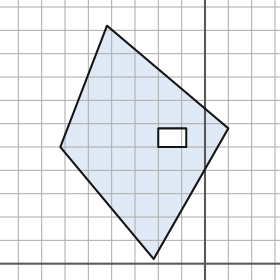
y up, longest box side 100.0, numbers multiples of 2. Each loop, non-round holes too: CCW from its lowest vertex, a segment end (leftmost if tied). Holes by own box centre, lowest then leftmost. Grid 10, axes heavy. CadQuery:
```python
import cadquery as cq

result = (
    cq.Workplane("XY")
    .moveTo(-22.0, 2.0)
    .lineTo(10.0, 58.0)
    .lineTo(-42.0, 102.0)
    .lineTo(-62.0, 50.0)
    .close()
    .moveTo(-20.0, 50.0)
    .lineTo(-8.0, 50.0)
    .lineTo(-8.0, 58.0)
    .lineTo(-20.0, 58.0)
    .close()
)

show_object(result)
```